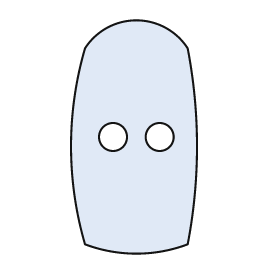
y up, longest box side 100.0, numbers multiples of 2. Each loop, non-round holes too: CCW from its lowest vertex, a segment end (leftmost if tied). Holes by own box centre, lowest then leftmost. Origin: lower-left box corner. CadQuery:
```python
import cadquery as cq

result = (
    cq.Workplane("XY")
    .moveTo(6.0, 4.0)
    .threePointArc((28.0, 0.0), (50.0, 4.0))
    .threePointArc((54.0, 46.0), (50.0, 88.0))
    .threePointArc((28.0, 100.0), (6.0, 88.0))
    .threePointArc((0.0, 46.0), (6.0, 4.0))
    .close()
    .moveTo(18.0, 50.0)
    .circle(6.0)
    .moveTo(38.0, 50.0)
    .circle(6.0)
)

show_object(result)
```